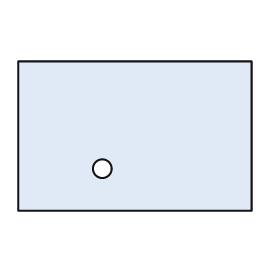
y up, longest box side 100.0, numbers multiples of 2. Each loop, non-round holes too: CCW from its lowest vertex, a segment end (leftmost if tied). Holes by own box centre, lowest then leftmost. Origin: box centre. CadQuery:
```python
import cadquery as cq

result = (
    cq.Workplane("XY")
    .moveTo(-50.0, -32.0)
    .lineTo(50.0, -32.0)
    .lineTo(50.0, 32.0)
    .lineTo(-50.0, 32.0)
    .close()
    .moveTo(-14.0, -14.0)
    .circle(4.0)
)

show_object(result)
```